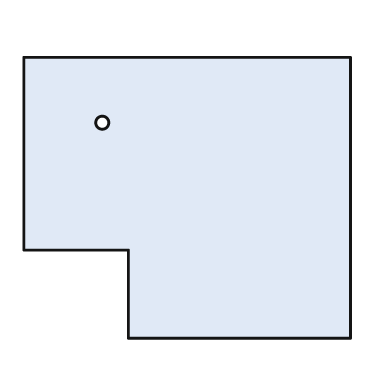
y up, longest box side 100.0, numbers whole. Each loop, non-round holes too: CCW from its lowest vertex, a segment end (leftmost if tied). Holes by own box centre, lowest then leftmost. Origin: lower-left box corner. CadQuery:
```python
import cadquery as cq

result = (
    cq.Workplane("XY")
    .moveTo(32.0, 0.0)
    .lineTo(100.0, 0.0)
    .lineTo(100.0, 86.0)
    .lineTo(0.0, 86.0)
    .lineTo(0.0, 27.0)
    .lineTo(32.0, 27.0)
    .close()
    .moveTo(24.0, 66.0)
    .circle(2.0)
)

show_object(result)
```